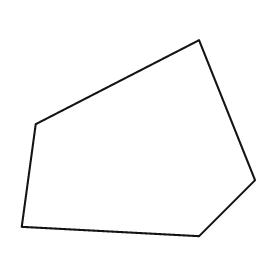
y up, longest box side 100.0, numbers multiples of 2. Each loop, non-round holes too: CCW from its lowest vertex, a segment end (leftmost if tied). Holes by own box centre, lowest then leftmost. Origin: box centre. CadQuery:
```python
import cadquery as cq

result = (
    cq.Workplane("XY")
    .moveTo(26.0, -42.0)
    .lineTo(50.0, -18.0)
    .lineTo(26.0, 42.0)
    .lineTo(-44.0, 6.0)
    .lineTo(-50.0, -38.0)
    .close()
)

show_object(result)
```